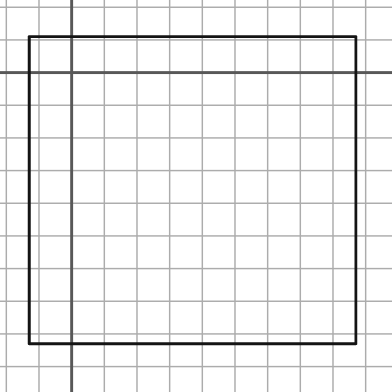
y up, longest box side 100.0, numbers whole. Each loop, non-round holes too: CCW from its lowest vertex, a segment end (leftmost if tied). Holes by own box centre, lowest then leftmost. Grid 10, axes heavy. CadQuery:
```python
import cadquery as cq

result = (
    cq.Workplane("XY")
    .moveTo(-13.0, -83.0)
    .lineTo(87.0, -83.0)
    .lineTo(87.0, 11.0)
    .lineTo(-13.0, 11.0)
    .close()
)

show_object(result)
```